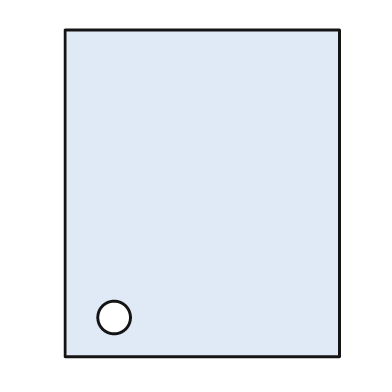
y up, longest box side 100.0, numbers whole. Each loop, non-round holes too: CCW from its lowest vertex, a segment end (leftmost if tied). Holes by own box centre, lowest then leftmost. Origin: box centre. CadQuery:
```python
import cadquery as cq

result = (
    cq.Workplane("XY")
    .moveTo(-42.0, -50.0)
    .lineTo(42.0, -50.0)
    .lineTo(42.0, 50.0)
    .lineTo(-42.0, 50.0)
    .close()
    .moveTo(-27.0, -38.0)
    .circle(5.0)
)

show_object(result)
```